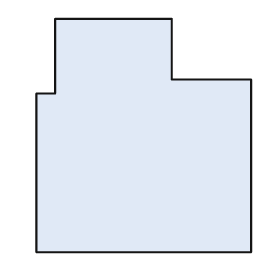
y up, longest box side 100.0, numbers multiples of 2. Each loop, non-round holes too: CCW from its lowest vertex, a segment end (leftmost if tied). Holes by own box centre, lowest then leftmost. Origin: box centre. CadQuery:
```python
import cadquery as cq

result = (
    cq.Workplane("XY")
    .moveTo(-46.0, -50.0)
    .lineTo(46.0, -50.0)
    .lineTo(46.0, 24.0)
    .lineTo(12.0, 24.0)
    .lineTo(12.0, 50.0)
    .lineTo(-38.0, 50.0)
    .lineTo(-38.0, 18.0)
    .lineTo(-46.0, 18.0)
    .close()
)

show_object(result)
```